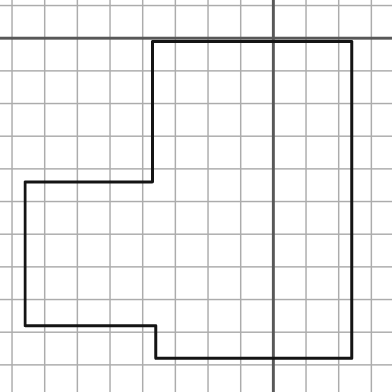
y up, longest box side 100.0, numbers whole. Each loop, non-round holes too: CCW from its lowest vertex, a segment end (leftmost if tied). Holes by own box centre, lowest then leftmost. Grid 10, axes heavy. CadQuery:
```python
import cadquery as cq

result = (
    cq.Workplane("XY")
    .moveTo(-36.0, -98.0)
    .lineTo(24.0, -98.0)
    .lineTo(24.0, -1.0)
    .lineTo(-37.0, -1.0)
    .lineTo(-37.0, -44.0)
    .lineTo(-76.0, -44.0)
    .lineTo(-76.0, -88.0)
    .lineTo(-36.0, -88.0)
    .close()
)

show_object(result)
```